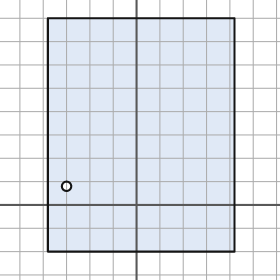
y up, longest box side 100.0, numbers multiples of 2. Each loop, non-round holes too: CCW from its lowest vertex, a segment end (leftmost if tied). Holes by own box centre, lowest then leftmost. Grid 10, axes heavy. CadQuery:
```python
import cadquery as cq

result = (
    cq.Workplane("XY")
    .moveTo(-38.0, -20.0)
    .lineTo(42.0, -20.0)
    .lineTo(42.0, 80.0)
    .lineTo(-38.0, 80.0)
    .close()
    .moveTo(-30.0, 8.0)
    .circle(2.0)
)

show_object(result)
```